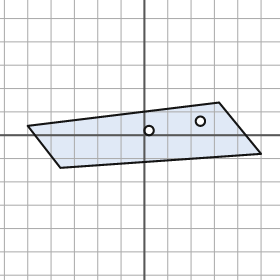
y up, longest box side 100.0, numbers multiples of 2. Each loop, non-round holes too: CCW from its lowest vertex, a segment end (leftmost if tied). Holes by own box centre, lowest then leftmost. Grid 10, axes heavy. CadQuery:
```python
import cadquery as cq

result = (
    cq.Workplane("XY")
    .moveTo(-36.0, -14.0)
    .lineTo(50.0, -8.0)
    .lineTo(32.0, 14.0)
    .lineTo(-50.0, 4.0)
    .close()
    .moveTo(2.0, 2.0)
    .circle(2.0)
    .moveTo(24.0, 6.0)
    .circle(2.0)
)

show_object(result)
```